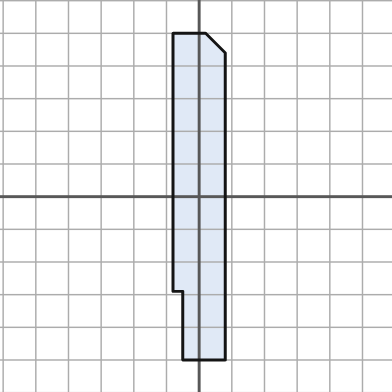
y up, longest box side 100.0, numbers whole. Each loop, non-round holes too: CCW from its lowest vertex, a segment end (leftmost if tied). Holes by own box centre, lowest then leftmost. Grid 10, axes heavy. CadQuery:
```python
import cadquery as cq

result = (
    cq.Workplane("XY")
    .moveTo(-5.0, -50.0)
    .lineTo(8.0, -50.0)
    .lineTo(8.0, 44.0)
    .lineTo(2.0, 50.0)
    .lineTo(-8.0, 50.0)
    .lineTo(-8.0, -29.0)
    .lineTo(-5.0, -29.0)
    .close()
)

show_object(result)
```